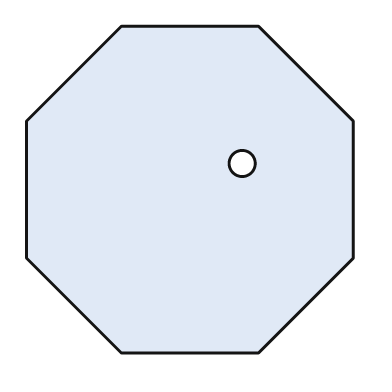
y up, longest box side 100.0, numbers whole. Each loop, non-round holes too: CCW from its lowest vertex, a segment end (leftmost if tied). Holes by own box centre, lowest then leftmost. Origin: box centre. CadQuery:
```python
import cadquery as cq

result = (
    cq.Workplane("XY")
    .moveTo(-21.0, -50.0)
    .lineTo(21.0, -50.0)
    .lineTo(50.0, -21.0)
    .lineTo(50.0, 21.0)
    .lineTo(21.0, 50.0)
    .lineTo(-21.0, 50.0)
    .lineTo(-50.0, 21.0)
    .lineTo(-50.0, -21.0)
    .close()
    .moveTo(16.0, 8.0)
    .circle(4.0)
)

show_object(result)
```